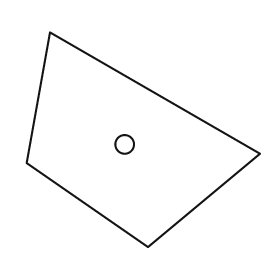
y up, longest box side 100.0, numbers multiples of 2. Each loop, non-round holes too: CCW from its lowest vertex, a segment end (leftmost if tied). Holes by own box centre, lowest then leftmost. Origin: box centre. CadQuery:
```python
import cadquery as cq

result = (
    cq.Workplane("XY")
    .moveTo(2.0, -46.0)
    .lineTo(50.0, -6.0)
    .lineTo(-40.0, 46.0)
    .lineTo(-50.0, -10.0)
    .close()
    .moveTo(-8.0, -2.0)
    .circle(4.0)
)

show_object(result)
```